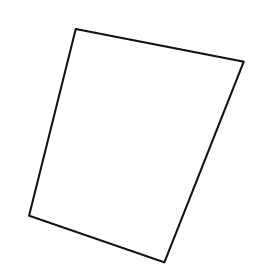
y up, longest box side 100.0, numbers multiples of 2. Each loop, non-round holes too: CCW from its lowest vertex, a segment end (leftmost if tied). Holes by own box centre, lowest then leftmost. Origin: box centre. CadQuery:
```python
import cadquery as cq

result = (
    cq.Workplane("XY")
    .moveTo(12.0, -50.0)
    .lineTo(46.0, 36.0)
    .lineTo(-26.0, 50.0)
    .lineTo(-46.0, -30.0)
    .close()
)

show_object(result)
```